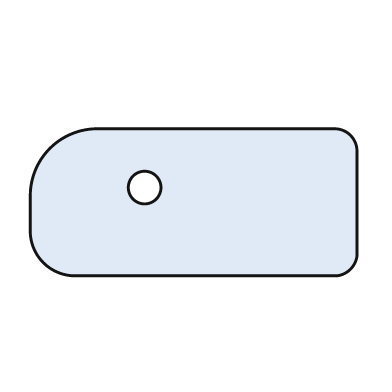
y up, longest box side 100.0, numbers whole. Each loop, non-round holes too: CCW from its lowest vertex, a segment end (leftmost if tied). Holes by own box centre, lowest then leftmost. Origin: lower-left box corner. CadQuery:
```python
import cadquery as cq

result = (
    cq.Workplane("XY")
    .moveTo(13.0, 0.0)
    .lineTo(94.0, 0.0)
    .threePointArc((98.0, 2.0), (100.0, 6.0))
    .lineTo(100.0, 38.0)
    .threePointArc((98.0, 43.0), (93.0, 45.0))
    .lineTo(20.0, 45.0)
    .threePointArc((6.0, 39.0), (0.0, 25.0))
    .lineTo(0.0, 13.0)
    .threePointArc((4.0, 4.0), (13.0, 0.0))
    .close()
    .moveTo(35.0, 27.0)
    .circle(5.0)
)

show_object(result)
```